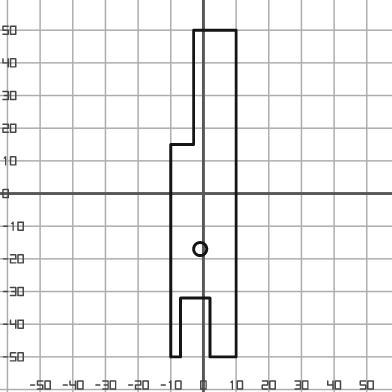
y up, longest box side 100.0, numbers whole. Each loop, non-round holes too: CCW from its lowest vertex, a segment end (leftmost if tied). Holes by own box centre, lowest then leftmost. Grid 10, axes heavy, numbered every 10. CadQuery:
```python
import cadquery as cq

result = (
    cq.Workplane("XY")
    .moveTo(-10.0, -50.0)
    .lineTo(-7.0, -50.0)
    .lineTo(-7.0, -32.0)
    .lineTo(2.0, -32.0)
    .lineTo(2.0, -50.0)
    .lineTo(10.0, -50.0)
    .lineTo(10.0, 50.0)
    .lineTo(-3.0, 50.0)
    .lineTo(-3.0, 15.0)
    .lineTo(-10.0, 15.0)
    .close()
    .moveTo(-1.0, -17.0)
    .circle(2.0)
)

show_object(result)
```